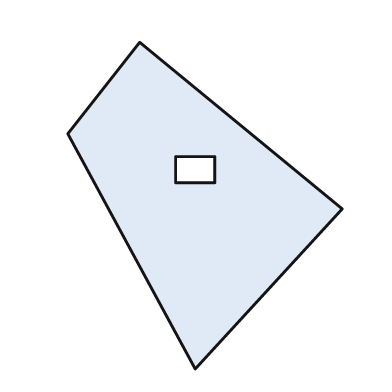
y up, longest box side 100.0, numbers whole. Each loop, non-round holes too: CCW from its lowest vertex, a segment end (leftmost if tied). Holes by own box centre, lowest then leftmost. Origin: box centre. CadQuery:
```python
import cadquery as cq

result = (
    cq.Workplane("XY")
    .moveTo(-3.0, -50.0)
    .lineTo(42.0, -1.0)
    .lineTo(-20.0, 50.0)
    .lineTo(-42.0, 22.0)
    .close()
    .moveTo(-9.0, 7.0)
    .lineTo(3.0, 7.0)
    .lineTo(3.0, 15.0)
    .lineTo(-9.0, 15.0)
    .close()
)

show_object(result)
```